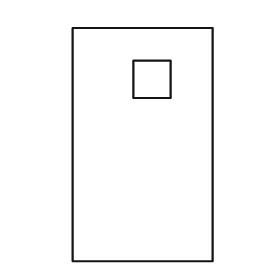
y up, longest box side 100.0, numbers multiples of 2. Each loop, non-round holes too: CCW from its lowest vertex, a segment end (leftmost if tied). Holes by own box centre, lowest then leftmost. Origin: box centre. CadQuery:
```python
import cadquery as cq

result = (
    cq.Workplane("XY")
    .moveTo(-30.0, -50.0)
    .lineTo(30.0, -50.0)
    .lineTo(30.0, 50.0)
    .lineTo(-30.0, 50.0)
    .close()
    .moveTo(-4.0, 20.0)
    .lineTo(12.0, 20.0)
    .lineTo(12.0, 36.0)
    .lineTo(-4.0, 36.0)
    .close()
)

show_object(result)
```